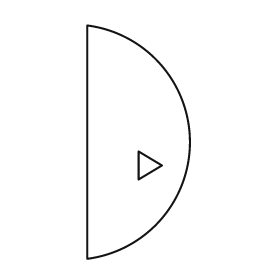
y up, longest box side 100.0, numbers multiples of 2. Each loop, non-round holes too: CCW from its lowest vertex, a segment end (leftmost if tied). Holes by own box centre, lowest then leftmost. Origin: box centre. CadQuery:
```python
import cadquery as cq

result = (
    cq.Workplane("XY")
    .moveTo(-22.0, -50.0)
    .threePointArc((22.0, 0.0), (-22.0, 50.0))
    .close()
    .moveTo(0.0, -16.0)
    .lineTo(10.0, -10.0)
    .lineTo(0.0, -4.0)
    .close()
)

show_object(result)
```